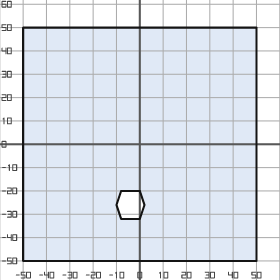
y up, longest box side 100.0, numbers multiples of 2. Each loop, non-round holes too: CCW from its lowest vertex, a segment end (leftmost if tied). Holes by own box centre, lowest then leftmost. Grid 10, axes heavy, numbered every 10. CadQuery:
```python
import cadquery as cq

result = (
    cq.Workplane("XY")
    .moveTo(-50.0, -50.0)
    .lineTo(50.0, -50.0)
    .lineTo(50.0, 50.0)
    .lineTo(-50.0, 50.0)
    .close()
    .moveTo(-8.0, -32.0)
    .lineTo(0.0, -32.0)
    .lineTo(2.0, -26.0)
    .lineTo(0.0, -20.0)
    .lineTo(-8.0, -20.0)
    .lineTo(-10.0, -26.0)
    .close()
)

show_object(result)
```